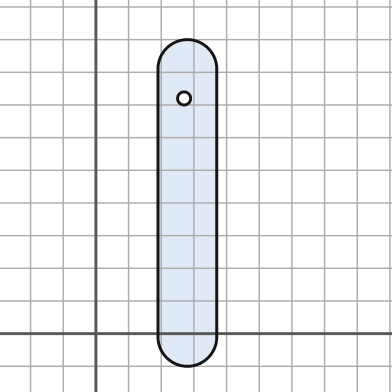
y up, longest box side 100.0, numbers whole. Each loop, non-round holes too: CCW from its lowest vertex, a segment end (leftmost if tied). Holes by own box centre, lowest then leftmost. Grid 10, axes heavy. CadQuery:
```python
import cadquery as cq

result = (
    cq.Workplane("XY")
    .moveTo(19.0, -1.0)
    .threePointArc((28.0, -10.0), (37.0, -1.0))
    .lineTo(37.0, 81.0)
    .threePointArc((28.0, 90.0), (19.0, 81.0))
    .close()
    .moveTo(27.0, 72.0)
    .circle(2.0)
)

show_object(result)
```